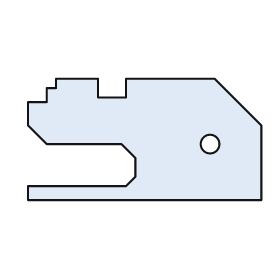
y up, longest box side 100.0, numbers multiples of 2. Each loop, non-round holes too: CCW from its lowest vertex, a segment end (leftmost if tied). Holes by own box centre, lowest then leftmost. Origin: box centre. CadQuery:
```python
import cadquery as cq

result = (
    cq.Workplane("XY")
    .moveTo(-50.0, -26.0)
    .lineTo(50.0, -26.0)
    .lineTo(50.0, 6.0)
    .lineTo(30.0, 26.0)
    .lineTo(-8.0, 26.0)
    .lineTo(-8.0, 18.0)
    .lineTo(-20.0, 18.0)
    .lineTo(-20.0, 26.0)
    .lineTo(-38.0, 26.0)
    .lineTo(-38.0, 22.0)
    .lineTo(-42.0, 22.0)
    .lineTo(-42.0, 16.0)
    .lineTo(-50.0, 16.0)
    .lineTo(-50.0, 6.0)
    .lineTo(-42.0, -2.0)
    .lineTo(-10.0, -2.0)
    .lineTo(-4.0, -8.0)
    .lineTo(-4.0, -16.0)
    .lineTo(-8.0, -20.0)
    .lineTo(-50.0, -20.0)
    .close()
    .moveTo(28.0, -2.0)
    .circle(4.0)
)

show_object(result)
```